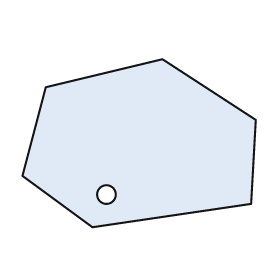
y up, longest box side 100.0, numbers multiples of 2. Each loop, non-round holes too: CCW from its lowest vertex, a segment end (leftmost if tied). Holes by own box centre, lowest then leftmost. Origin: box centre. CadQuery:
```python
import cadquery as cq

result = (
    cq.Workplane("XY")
    .moveTo(-20.0, -36.0)
    .lineTo(48.0, -26.0)
    .lineTo(50.0, 10.0)
    .lineTo(10.0, 36.0)
    .lineTo(-40.0, 24.0)
    .lineTo(-50.0, -14.0)
    .close()
    .moveTo(-14.0, -22.0)
    .circle(4.0)
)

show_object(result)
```